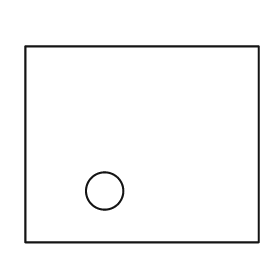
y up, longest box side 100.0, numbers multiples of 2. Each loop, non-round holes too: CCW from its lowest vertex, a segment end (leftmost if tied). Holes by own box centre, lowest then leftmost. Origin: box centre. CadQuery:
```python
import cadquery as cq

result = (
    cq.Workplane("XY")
    .moveTo(-50.0, -42.0)
    .lineTo(50.0, -42.0)
    .lineTo(50.0, 42.0)
    .lineTo(-50.0, 42.0)
    .close()
    .moveTo(-16.0, -20.0)
    .circle(8.0)
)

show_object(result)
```